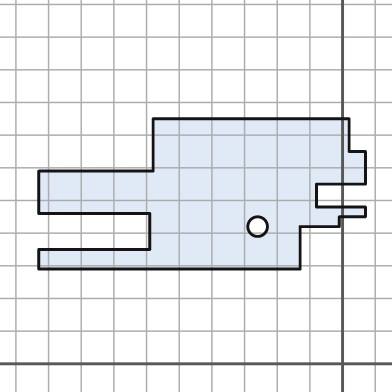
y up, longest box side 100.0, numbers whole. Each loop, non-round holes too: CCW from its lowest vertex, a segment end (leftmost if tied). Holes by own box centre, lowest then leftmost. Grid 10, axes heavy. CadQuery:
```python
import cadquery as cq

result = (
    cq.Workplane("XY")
    .moveTo(-93.0, 29.0)
    .lineTo(-13.0, 29.0)
    .lineTo(-13.0, 42.0)
    .lineTo(-1.0, 42.0)
    .lineTo(-1.0, 45.0)
    .lineTo(7.0, 45.0)
    .lineTo(7.0, 48.0)
    .lineTo(-8.0, 48.0)
    .lineTo(-8.0, 55.0)
    .lineTo(7.0, 55.0)
    .lineTo(7.0, 65.0)
    .lineTo(2.0, 65.0)
    .lineTo(2.0, 75.0)
    .lineTo(-58.0, 75.0)
    .lineTo(-58.0, 59.0)
    .lineTo(-93.0, 59.0)
    .lineTo(-93.0, 46.0)
    .lineTo(-59.0, 46.0)
    .lineTo(-59.0, 35.0)
    .lineTo(-93.0, 35.0)
    .close()
    .moveTo(-26.0, 42.0)
    .circle(3.0)
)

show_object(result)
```